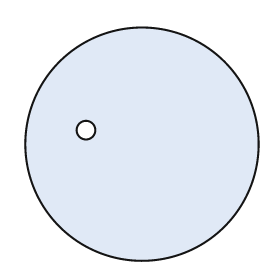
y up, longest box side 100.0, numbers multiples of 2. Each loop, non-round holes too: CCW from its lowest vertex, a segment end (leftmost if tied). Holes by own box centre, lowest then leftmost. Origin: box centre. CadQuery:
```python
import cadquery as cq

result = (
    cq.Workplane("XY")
    .moveTo(0.0, 0.0)
    .circle(50.0)
    .moveTo(-24.0, 6.0)
    .circle(4.0)
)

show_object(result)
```